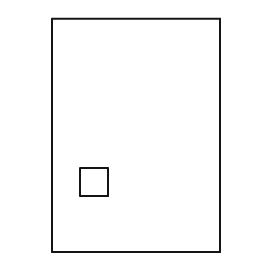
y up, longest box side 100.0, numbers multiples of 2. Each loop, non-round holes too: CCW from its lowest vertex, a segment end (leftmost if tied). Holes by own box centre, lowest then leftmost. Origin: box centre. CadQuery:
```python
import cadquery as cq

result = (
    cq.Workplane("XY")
    .moveTo(-36.0, -50.0)
    .lineTo(36.0, -50.0)
    .lineTo(36.0, 50.0)
    .lineTo(-36.0, 50.0)
    .close()
    .moveTo(-24.0, -26.0)
    .lineTo(-12.0, -26.0)
    .lineTo(-12.0, -14.0)
    .lineTo(-24.0, -14.0)
    .close()
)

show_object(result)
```